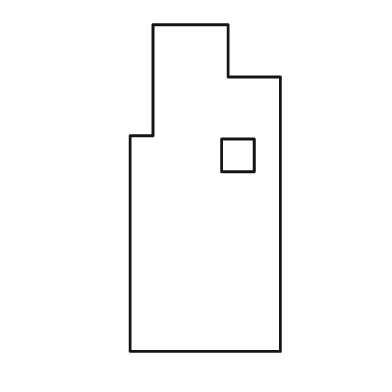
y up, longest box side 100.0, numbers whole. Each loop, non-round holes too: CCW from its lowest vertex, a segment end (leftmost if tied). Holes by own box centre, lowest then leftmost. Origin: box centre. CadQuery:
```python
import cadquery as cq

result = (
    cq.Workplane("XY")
    .moveTo(-23.0, -50.0)
    .lineTo(23.0, -50.0)
    .lineTo(23.0, 34.0)
    .lineTo(7.0, 34.0)
    .lineTo(7.0, 50.0)
    .lineTo(-16.0, 50.0)
    .lineTo(-16.0, 16.0)
    .lineTo(-23.0, 16.0)
    .close()
    .moveTo(5.0, 5.0)
    .lineTo(15.0, 5.0)
    .lineTo(15.0, 15.0)
    .lineTo(5.0, 15.0)
    .close()
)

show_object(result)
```